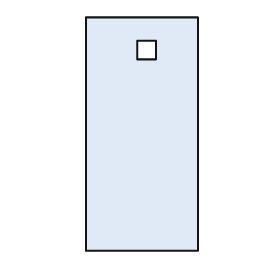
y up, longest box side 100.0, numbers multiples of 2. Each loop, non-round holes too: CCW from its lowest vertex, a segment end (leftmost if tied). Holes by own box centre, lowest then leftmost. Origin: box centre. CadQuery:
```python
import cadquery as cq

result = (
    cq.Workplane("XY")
    .moveTo(-24.0, -50.0)
    .lineTo(24.0, -50.0)
    .lineTo(24.0, 50.0)
    .lineTo(-24.0, 50.0)
    .close()
    .moveTo(-2.0, 32.0)
    .lineTo(6.0, 32.0)
    .lineTo(6.0, 40.0)
    .lineTo(-2.0, 40.0)
    .close()
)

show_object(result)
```